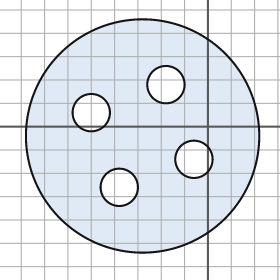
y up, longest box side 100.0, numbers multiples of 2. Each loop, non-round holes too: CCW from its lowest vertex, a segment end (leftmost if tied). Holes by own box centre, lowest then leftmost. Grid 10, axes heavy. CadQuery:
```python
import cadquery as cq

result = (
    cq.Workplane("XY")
    .moveTo(-28.0, -4.0)
    .circle(50.0)
    .moveTo(-38.0, -26.0)
    .circle(8.0)
    .moveTo(-6.0, -14.0)
    .circle(8.0)
    .moveTo(-50.0, 6.0)
    .circle(8.0)
    .moveTo(-18.0, 18.0)
    .circle(8.0)
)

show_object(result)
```